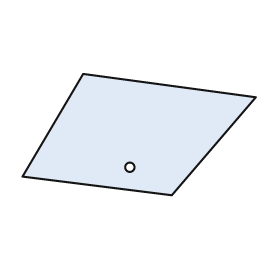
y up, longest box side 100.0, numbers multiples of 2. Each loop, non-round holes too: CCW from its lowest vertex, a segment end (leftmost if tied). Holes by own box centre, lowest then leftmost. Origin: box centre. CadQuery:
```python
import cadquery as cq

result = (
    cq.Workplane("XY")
    .moveTo(14.0, -26.0)
    .lineTo(50.0, 16.0)
    .lineTo(-24.0, 26.0)
    .lineTo(-50.0, -18.0)
    .close()
    .moveTo(-4.0, -14.0)
    .circle(2.0)
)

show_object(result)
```